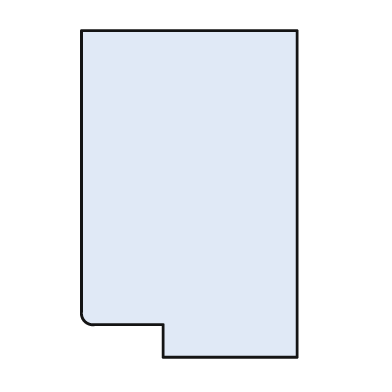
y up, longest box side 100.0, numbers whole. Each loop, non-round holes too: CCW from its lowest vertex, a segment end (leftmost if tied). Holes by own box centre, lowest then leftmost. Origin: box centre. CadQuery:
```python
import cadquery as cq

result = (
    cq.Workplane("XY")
    .moveTo(-8.0, -50.0)
    .lineTo(33.0, -50.0)
    .lineTo(33.0, 50.0)
    .lineTo(-33.0, 50.0)
    .lineTo(-33.0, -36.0)
    .threePointArc((-32.0, -39.0), (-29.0, -40.0))
    .lineTo(-8.0, -40.0)
    .close()
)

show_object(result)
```